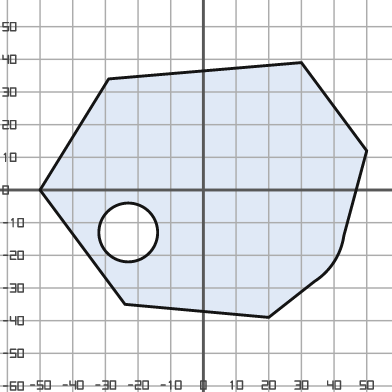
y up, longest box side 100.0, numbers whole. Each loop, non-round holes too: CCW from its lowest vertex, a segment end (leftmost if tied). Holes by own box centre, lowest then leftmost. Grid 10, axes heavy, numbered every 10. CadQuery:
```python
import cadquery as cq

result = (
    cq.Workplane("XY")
    .moveTo(20.0, -39.0)
    .lineTo(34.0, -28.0)
    .threePointArc((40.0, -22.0), (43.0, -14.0))
    .lineTo(50.0, 12.0)
    .lineTo(30.0, 39.0)
    .lineTo(-29.0, 34.0)
    .lineTo(-50.0, 0.0)
    .lineTo(-24.0, -35.0)
    .close()
    .moveTo(-23.0, -13.0)
    .circle(9.0)
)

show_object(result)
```